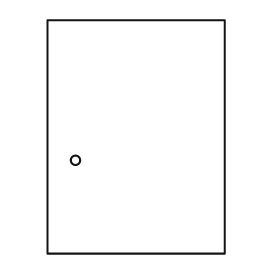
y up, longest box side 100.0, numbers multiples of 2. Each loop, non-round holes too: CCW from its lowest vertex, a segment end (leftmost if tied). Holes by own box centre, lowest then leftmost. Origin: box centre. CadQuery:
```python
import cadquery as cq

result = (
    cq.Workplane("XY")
    .moveTo(-38.0, -50.0)
    .lineTo(38.0, -50.0)
    .lineTo(38.0, 50.0)
    .lineTo(-38.0, 50.0)
    .close()
    .moveTo(-26.0, -10.0)
    .circle(2.0)
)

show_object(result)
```